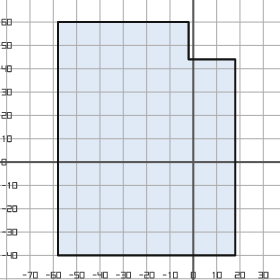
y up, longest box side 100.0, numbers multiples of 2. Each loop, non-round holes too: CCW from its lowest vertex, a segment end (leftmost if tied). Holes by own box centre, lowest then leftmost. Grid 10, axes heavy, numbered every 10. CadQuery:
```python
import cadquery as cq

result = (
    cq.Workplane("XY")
    .moveTo(-58.0, -40.0)
    .lineTo(18.0, -40.0)
    .lineTo(18.0, 44.0)
    .lineTo(-2.0, 44.0)
    .lineTo(-2.0, 60.0)
    .lineTo(-58.0, 60.0)
    .close()
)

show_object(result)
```